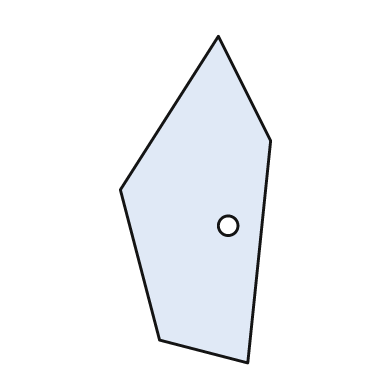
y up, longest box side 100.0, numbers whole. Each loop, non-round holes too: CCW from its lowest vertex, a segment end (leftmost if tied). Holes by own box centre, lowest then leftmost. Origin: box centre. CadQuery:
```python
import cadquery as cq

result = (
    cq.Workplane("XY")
    .moveTo(16.0, -50.0)
    .lineTo(23.0, 18.0)
    .lineTo(7.0, 50.0)
    .lineTo(-23.0, 3.0)
    .lineTo(-11.0, -43.0)
    .close()
    .moveTo(10.0, -8.0)
    .circle(3.0)
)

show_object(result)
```